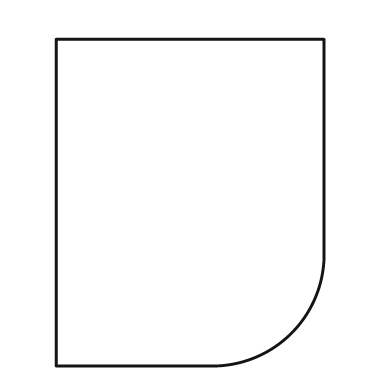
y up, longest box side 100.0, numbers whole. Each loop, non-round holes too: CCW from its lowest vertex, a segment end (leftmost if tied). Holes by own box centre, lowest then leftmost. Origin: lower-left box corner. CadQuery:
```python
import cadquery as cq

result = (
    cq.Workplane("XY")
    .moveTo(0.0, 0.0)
    .lineTo(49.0, 0.0)
    .threePointArc((72.0, 10.0), (82.0, 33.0))
    .lineTo(82.0, 100.0)
    .lineTo(0.0, 100.0)
    .close()
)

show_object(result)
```